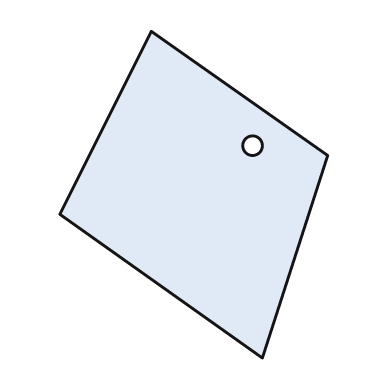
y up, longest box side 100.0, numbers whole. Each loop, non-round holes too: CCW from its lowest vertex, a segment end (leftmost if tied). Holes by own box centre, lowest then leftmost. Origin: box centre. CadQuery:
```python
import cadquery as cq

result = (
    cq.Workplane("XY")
    .moveTo(21.0, -50.0)
    .lineTo(41.0, 12.0)
    .lineTo(-13.0, 50.0)
    .lineTo(-41.0, -6.0)
    .close()
    .moveTo(18.0, 15.0)
    .circle(3.0)
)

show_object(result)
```